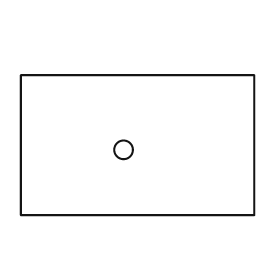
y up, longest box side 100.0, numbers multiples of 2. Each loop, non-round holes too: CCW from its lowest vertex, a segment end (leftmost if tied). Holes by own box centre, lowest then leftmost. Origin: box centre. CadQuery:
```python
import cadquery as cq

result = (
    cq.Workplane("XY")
    .moveTo(-50.0, -30.0)
    .lineTo(50.0, -30.0)
    .lineTo(50.0, 30.0)
    .lineTo(-50.0, 30.0)
    .close()
    .moveTo(-6.0, -2.0)
    .circle(4.0)
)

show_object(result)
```